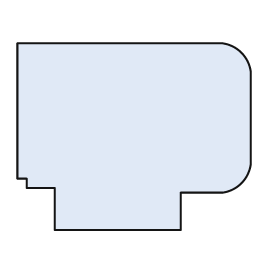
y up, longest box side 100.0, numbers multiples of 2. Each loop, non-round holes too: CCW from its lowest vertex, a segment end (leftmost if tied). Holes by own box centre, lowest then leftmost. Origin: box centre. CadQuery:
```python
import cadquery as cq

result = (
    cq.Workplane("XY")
    .moveTo(-34.0, -40.0)
    .lineTo(20.0, -40.0)
    .lineTo(20.0, -24.0)
    .lineTo(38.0, -24.0)
    .threePointArc((46.0, -20.0), (50.0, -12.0))
    .lineTo(50.0, 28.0)
    .threePointArc((46.0, 36.0), (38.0, 40.0))
    .lineTo(-50.0, 40.0)
    .lineTo(-50.0, -18.0)
    .lineTo(-46.0, -18.0)
    .lineTo(-46.0, -22.0)
    .lineTo(-34.0, -22.0)
    .close()
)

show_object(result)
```